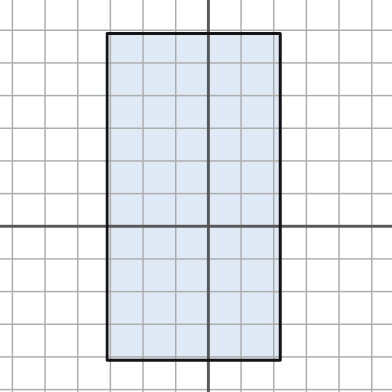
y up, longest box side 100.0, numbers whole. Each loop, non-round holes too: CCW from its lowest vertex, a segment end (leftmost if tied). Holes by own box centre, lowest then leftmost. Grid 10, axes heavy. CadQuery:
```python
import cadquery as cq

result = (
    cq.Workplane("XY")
    .moveTo(-31.0, -41.0)
    .lineTo(22.0, -41.0)
    .lineTo(22.0, 59.0)
    .lineTo(-31.0, 59.0)
    .close()
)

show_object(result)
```